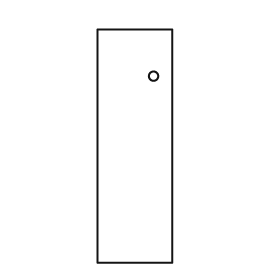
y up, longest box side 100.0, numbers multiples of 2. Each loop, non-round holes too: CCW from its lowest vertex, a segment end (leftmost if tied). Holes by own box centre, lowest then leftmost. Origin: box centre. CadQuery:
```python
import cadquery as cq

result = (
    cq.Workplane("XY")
    .moveTo(-16.0, -50.0)
    .lineTo(16.0, -50.0)
    .lineTo(16.0, 50.0)
    .lineTo(-16.0, 50.0)
    .close()
    .moveTo(8.0, 30.0)
    .circle(2.0)
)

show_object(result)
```